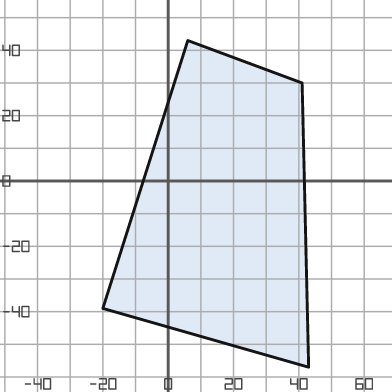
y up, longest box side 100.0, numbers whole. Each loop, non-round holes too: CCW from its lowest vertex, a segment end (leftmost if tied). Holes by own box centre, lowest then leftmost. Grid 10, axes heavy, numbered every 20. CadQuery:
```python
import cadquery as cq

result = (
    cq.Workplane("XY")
    .moveTo(43.0, -57.0)
    .lineTo(41.0, 30.0)
    .lineTo(6.0, 43.0)
    .lineTo(-20.0, -39.0)
    .close()
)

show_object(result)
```